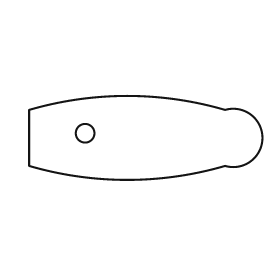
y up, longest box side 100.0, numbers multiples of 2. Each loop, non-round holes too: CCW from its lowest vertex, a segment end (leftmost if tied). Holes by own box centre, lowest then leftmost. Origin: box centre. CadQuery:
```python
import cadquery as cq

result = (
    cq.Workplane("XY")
    .moveTo(-50.0, -12.0)
    .threePointArc((-8.0, -18.0), (34.0, -12.0))
    .threePointArc((50.0, 0.0), (34.0, 12.0))
    .threePointArc((-8.0, 18.0), (-50.0, 12.0))
    .close()
    .moveTo(-26.0, 2.0)
    .circle(4.0)
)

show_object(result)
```